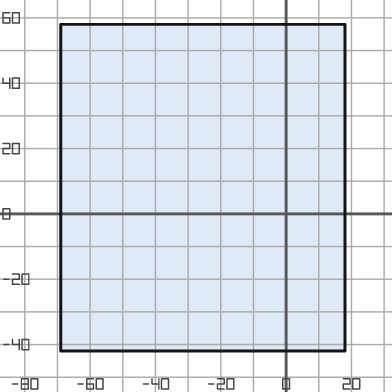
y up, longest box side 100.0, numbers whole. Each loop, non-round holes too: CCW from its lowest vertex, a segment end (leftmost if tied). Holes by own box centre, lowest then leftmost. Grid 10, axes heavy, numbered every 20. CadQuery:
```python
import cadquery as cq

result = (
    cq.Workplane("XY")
    .moveTo(-69.0, -42.0)
    .lineTo(18.0, -42.0)
    .lineTo(18.0, 58.0)
    .lineTo(-69.0, 58.0)
    .close()
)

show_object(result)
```